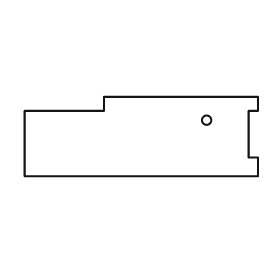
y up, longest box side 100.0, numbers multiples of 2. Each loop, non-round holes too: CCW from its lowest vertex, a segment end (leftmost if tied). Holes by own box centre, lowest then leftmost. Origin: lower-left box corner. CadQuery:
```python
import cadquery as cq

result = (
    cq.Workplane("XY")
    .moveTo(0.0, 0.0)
    .lineTo(100.0, 0.0)
    .lineTo(100.0, 8.0)
    .lineTo(96.0, 8.0)
    .lineTo(96.0, 28.0)
    .lineTo(100.0, 28.0)
    .lineTo(100.0, 34.0)
    .lineTo(34.0, 34.0)
    .lineTo(34.0, 28.0)
    .lineTo(0.0, 28.0)
    .close()
    .moveTo(78.0, 24.0)
    .circle(2.0)
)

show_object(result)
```